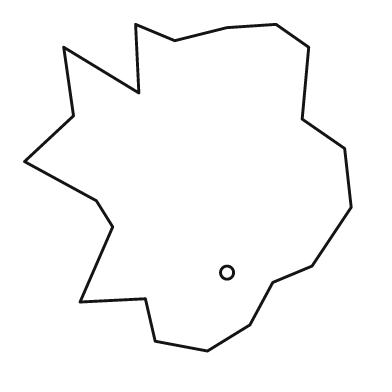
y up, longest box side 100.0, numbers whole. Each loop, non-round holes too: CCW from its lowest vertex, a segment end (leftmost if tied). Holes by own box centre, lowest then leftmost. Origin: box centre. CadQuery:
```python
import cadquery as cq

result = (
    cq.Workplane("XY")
    .moveTo(6.0, -50.0)
    .lineTo(19.0, -42.0)
    .lineTo(26.0, -29.0)
    .lineTo(38.0, -24.0)
    .lineTo(50.0, -6.0)
    .lineTo(48.0, 12.0)
    .lineTo(35.0, 21.0)
    .lineTo(37.0, 43.0)
    .lineTo(27.0, 50.0)
    .lineTo(12.0, 49.0)
    .lineTo(-4.0, 45.0)
    .lineTo(-16.0, 50.0)
    .lineTo(-15.0, 29.0)
    .lineTo(-38.0, 43.0)
    .lineTo(-35.0, 22.0)
    .lineTo(-50.0, 8.0)
    .lineTo(-28.0, -4.0)
    .lineTo(-23.0, -12.0)
    .lineTo(-33.0, -35.0)
    .lineTo(-13.0, -34.0)
    .lineTo(-10.0, -47.0)
    .close()
    .moveTo(12.0, -26.0)
    .circle(2.0)
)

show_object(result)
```